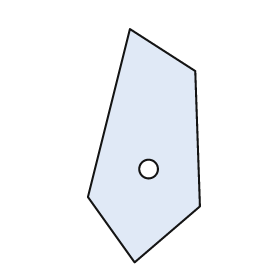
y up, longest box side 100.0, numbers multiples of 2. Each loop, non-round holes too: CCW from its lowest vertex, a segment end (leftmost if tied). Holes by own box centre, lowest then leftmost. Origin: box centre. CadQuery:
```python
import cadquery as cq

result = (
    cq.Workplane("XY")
    .moveTo(-4.0, -50.0)
    .lineTo(24.0, -26.0)
    .lineTo(22.0, 32.0)
    .lineTo(-6.0, 50.0)
    .lineTo(-24.0, -22.0)
    .close()
    .moveTo(2.0, -10.0)
    .circle(4.0)
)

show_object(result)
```